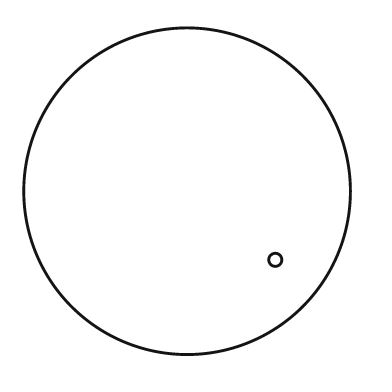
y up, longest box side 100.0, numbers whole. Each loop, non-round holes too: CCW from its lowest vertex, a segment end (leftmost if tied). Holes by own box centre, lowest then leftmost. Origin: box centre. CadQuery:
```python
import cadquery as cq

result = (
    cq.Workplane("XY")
    .moveTo(0.0, 0.0)
    .circle(50.0)
    .moveTo(27.0, -21.0)
    .circle(2.0)
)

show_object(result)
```